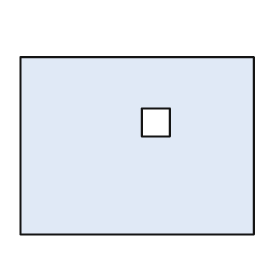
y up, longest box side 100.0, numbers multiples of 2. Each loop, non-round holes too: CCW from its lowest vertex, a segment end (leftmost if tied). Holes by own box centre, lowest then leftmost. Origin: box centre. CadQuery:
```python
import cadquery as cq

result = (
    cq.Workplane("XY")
    .moveTo(-50.0, -38.0)
    .lineTo(50.0, -38.0)
    .lineTo(50.0, 38.0)
    .lineTo(-50.0, 38.0)
    .close()
    .moveTo(2.0, 4.0)
    .lineTo(14.0, 4.0)
    .lineTo(14.0, 16.0)
    .lineTo(2.0, 16.0)
    .close()
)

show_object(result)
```